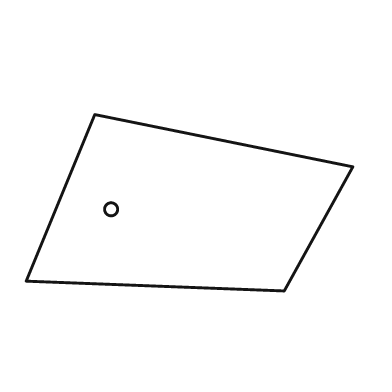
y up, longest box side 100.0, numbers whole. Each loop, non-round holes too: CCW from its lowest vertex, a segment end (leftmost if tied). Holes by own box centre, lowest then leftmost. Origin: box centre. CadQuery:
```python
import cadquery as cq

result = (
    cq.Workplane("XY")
    .moveTo(29.0, -27.0)
    .lineTo(50.0, 11.0)
    .lineTo(-29.0, 27.0)
    .lineTo(-50.0, -24.0)
    .close()
    .moveTo(-24.0, -2.0)
    .circle(2.0)
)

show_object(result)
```